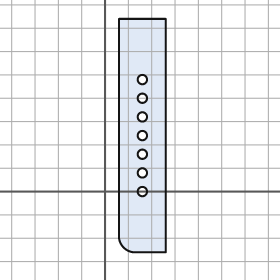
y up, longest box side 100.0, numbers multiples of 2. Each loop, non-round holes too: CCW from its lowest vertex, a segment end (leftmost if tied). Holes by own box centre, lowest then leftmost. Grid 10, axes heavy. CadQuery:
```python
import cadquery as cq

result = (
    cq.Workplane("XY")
    .moveTo(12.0, -26.0)
    .lineTo(26.0, -26.0)
    .lineTo(26.0, 74.0)
    .lineTo(6.0, 74.0)
    .lineTo(6.0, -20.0)
    .threePointArc((8.0, -24.0), (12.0, -26.0))
    .close()
    .moveTo(16.0, 0.0)
    .circle(2.0)
    .moveTo(16.0, 8.0)
    .circle(2.0)
    .moveTo(16.0, 16.0)
    .circle(2.0)
    .moveTo(16.0, 24.0)
    .circle(2.0)
    .moveTo(16.0, 32.0)
    .circle(2.0)
    .moveTo(16.0, 40.0)
    .circle(2.0)
    .moveTo(16.0, 48.0)
    .circle(2.0)
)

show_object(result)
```